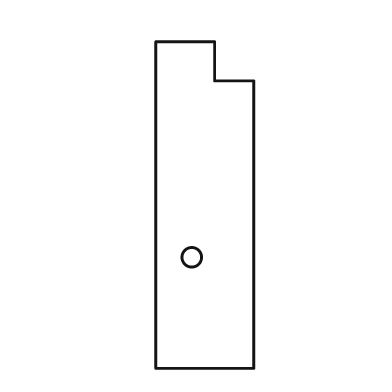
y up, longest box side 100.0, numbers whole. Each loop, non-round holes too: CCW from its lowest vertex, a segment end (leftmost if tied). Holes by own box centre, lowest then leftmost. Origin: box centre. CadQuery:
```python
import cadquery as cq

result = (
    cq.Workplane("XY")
    .moveTo(-15.0, -50.0)
    .lineTo(15.0, -50.0)
    .lineTo(15.0, 38.0)
    .lineTo(3.0, 38.0)
    .lineTo(3.0, 50.0)
    .lineTo(-15.0, 50.0)
    .close()
    .moveTo(-4.0, -16.0)
    .circle(3.0)
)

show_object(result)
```